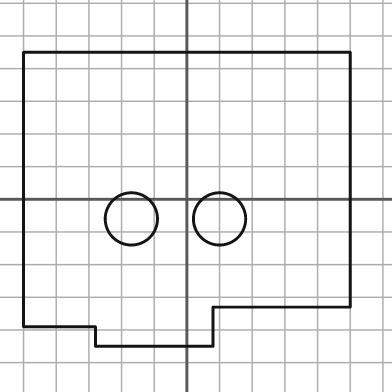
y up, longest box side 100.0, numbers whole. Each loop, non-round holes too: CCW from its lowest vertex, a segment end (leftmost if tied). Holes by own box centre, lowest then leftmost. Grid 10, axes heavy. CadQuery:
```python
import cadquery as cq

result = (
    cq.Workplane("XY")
    .moveTo(-28.0, -45.0)
    .lineTo(8.0, -45.0)
    .lineTo(8.0, -33.0)
    .lineTo(50.0, -33.0)
    .lineTo(50.0, 45.0)
    .lineTo(-50.0, 45.0)
    .lineTo(-50.0, -39.0)
    .lineTo(-28.0, -39.0)
    .close()
    .moveTo(-17.0, -6.0)
    .circle(8.0)
    .moveTo(10.0, -6.0)
    .circle(8.0)
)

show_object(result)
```